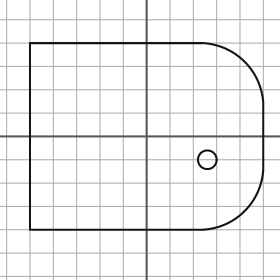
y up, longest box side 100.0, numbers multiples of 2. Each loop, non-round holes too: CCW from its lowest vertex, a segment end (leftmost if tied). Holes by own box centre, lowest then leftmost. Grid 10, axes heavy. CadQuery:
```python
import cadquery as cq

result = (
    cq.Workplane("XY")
    .moveTo(-50.0, -40.0)
    .lineTo(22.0, -40.0)
    .threePointArc((42.0, -32.0), (50.0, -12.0))
    .lineTo(50.0, 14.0)
    .threePointArc((42.0, 32.0), (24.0, 40.0))
    .lineTo(-50.0, 40.0)
    .close()
    .moveTo(26.0, -10.0)
    .circle(4.0)
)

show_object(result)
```